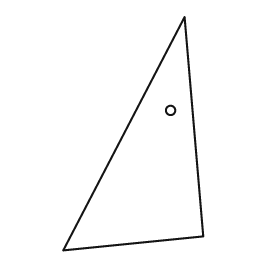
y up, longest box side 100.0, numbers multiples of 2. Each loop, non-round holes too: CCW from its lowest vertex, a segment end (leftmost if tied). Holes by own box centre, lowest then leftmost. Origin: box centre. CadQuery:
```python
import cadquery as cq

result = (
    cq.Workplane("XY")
    .moveTo(-30.0, -50.0)
    .lineTo(30.0, -44.0)
    .lineTo(22.0, 50.0)
    .close()
    .moveTo(16.0, 10.0)
    .circle(2.0)
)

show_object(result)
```